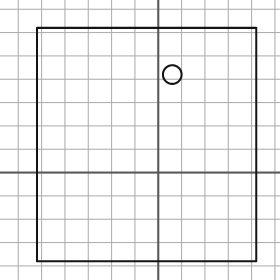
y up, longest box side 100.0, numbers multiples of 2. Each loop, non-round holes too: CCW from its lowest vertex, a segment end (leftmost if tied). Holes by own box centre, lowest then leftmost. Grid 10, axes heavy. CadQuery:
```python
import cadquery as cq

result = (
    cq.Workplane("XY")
    .moveTo(-52.0, -38.0)
    .lineTo(42.0, -38.0)
    .lineTo(42.0, 62.0)
    .lineTo(-52.0, 62.0)
    .close()
    .moveTo(6.0, 42.0)
    .circle(4.0)
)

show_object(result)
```